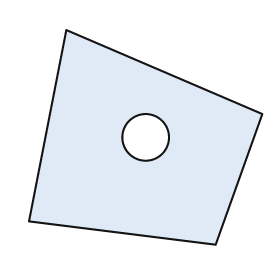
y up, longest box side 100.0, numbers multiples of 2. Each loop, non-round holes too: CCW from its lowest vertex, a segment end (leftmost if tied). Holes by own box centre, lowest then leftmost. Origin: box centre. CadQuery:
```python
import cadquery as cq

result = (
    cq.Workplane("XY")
    .moveTo(30.0, -46.0)
    .lineTo(50.0, 10.0)
    .lineTo(-34.0, 46.0)
    .lineTo(-50.0, -36.0)
    .close()
    .moveTo(0.0, 0.0)
    .circle(10.0)
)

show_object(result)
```